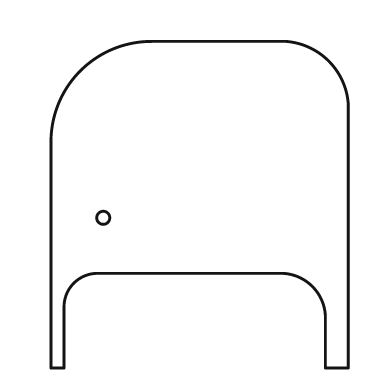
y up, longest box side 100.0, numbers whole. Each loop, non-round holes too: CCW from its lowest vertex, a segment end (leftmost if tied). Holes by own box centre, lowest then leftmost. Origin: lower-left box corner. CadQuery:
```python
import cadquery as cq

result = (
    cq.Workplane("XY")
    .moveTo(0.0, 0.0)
    .lineTo(4.0, 0.0)
    .lineTo(4.0, 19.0)
    .threePointArc((7.0, 26.0), (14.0, 29.0))
    .lineTo(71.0, 29.0)
    .threePointArc((80.0, 25.0), (84.0, 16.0))
    .lineTo(84.0, 0.0)
    .lineTo(91.0, 0.0)
    .lineTo(91.0, 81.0)
    .threePointArc((85.0, 94.0), (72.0, 100.0))
    .lineTo(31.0, 100.0)
    .threePointArc((9.0, 91.0), (0.0, 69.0))
    .close()
    .moveTo(16.0, 46.0)
    .circle(2.0)
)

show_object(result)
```